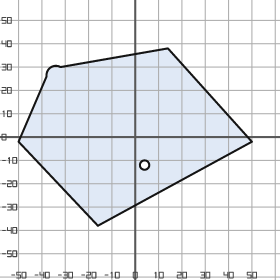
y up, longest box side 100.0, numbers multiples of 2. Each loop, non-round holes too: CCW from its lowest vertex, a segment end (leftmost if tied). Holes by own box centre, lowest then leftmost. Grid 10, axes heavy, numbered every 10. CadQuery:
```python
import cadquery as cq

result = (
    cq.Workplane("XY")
    .moveTo(-16.0, -38.0)
    .lineTo(50.0, -2.0)
    .lineTo(14.0, 38.0)
    .lineTo(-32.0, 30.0)
    .threePointArc((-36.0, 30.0), (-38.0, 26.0))
    .lineTo(-50.0, -2.0)
    .close()
    .moveTo(4.0, -12.0)
    .circle(2.0)
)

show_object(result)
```